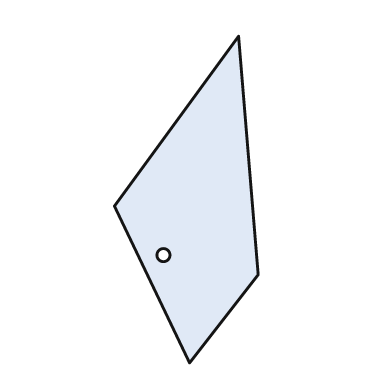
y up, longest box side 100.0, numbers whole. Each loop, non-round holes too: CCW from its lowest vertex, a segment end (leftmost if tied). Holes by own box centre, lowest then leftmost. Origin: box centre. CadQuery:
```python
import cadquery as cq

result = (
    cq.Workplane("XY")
    .moveTo(1.0, -50.0)
    .lineTo(22.0, -23.0)
    .lineTo(16.0, 50.0)
    .lineTo(-22.0, -2.0)
    .close()
    .moveTo(-7.0, -17.0)
    .circle(2.0)
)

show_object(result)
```